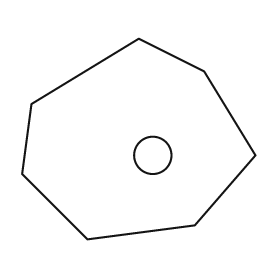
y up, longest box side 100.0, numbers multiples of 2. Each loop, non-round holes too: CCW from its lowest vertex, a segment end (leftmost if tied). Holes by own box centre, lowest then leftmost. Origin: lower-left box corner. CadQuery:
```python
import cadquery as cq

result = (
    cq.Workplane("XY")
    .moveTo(28.0, 0.0)
    .lineTo(74.0, 6.0)
    .lineTo(100.0, 36.0)
    .lineTo(78.0, 72.0)
    .lineTo(50.0, 86.0)
    .lineTo(4.0, 58.0)
    .lineTo(0.0, 28.0)
    .close()
    .moveTo(56.0, 36.0)
    .circle(8.0)
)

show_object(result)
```